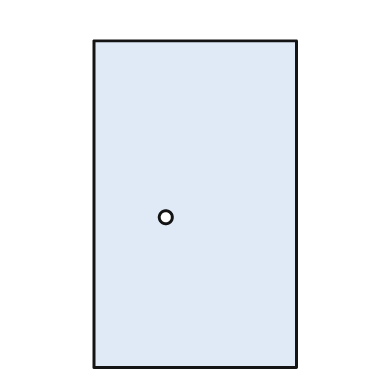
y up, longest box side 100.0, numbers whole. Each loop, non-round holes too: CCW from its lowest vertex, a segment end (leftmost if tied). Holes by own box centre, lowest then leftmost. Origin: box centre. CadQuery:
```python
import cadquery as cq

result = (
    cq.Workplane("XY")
    .moveTo(-31.0, -50.0)
    .lineTo(31.0, -50.0)
    .lineTo(31.0, 50.0)
    .lineTo(-31.0, 50.0)
    .close()
    .moveTo(-9.0, -4.0)
    .circle(2.0)
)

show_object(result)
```